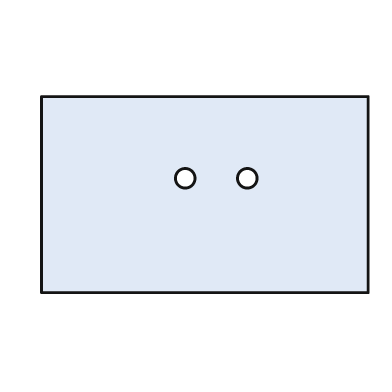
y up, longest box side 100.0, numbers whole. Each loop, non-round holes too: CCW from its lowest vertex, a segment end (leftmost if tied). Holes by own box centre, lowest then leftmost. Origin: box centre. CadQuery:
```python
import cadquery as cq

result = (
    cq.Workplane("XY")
    .moveTo(-50.0, -30.0)
    .lineTo(50.0, -30.0)
    .lineTo(50.0, 30.0)
    .lineTo(-50.0, 30.0)
    .close()
    .moveTo(-6.0, 5.0)
    .circle(3.0)
    .moveTo(13.0, 5.0)
    .circle(3.0)
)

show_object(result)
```